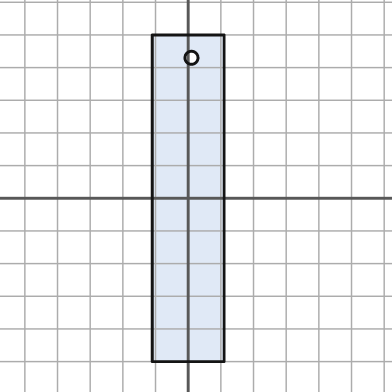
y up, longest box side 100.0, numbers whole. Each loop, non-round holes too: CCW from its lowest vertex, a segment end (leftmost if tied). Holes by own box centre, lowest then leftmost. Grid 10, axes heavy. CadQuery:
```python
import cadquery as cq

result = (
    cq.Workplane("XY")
    .moveTo(-11.0, -50.0)
    .lineTo(11.0, -50.0)
    .lineTo(11.0, 50.0)
    .lineTo(-11.0, 50.0)
    .close()
    .moveTo(1.0, 43.0)
    .circle(2.0)
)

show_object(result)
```